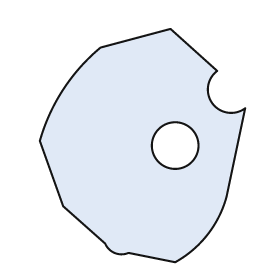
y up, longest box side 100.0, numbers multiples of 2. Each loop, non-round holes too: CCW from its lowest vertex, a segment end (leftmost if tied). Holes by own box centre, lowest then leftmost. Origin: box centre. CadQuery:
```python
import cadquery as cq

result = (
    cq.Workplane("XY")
    .moveTo(14.0, -50.0)
    .threePointArc((28.0, -38.0), (36.0, -22.0))
    .lineTo(44.0, 16.0)
    .threePointArc((30.0, 18.0), (32.0, 32.0))
    .lineTo(12.0, 50.0)
    .lineTo(-18.0, 42.0)
    .threePointArc((-34.0, 24.0), (-44.0, 2.0))
    .lineTo(-34.0, -26.0)
    .lineTo(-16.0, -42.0)
    .threePointArc((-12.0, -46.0), (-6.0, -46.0))
    .close()
    .moveTo(14.0, 0.0)
    .circle(10.0)
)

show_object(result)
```